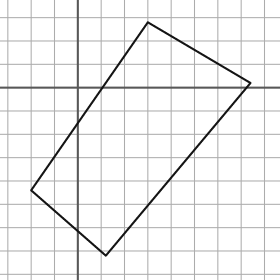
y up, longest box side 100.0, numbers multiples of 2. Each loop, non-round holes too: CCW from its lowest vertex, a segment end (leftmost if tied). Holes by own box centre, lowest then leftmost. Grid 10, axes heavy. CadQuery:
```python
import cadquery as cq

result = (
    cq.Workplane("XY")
    .moveTo(12.0, -72.0)
    .lineTo(74.0, 2.0)
    .lineTo(30.0, 28.0)
    .lineTo(-20.0, -44.0)
    .close()
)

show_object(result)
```